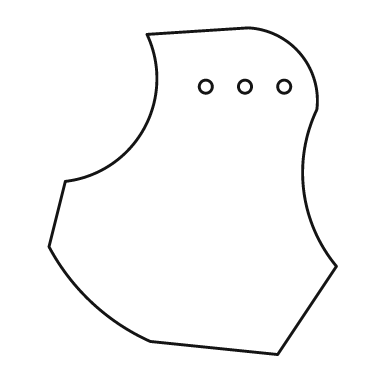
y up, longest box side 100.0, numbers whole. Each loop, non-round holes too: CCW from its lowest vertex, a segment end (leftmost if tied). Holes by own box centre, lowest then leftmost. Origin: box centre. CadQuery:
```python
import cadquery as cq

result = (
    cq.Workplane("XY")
    .moveTo(26.0, -50.0)
    .lineTo(44.0, -23.0)
    .threePointArc((34.0, 0.0), (38.0, 25.0))
    .threePointArc((33.0, 42.0), (17.0, 50.0))
    .lineTo(-14.0, 48.0)
    .threePointArc((-15.0, 19.0), (-39.0, 3.0))
    .lineTo(-44.0, -17.0)
    .threePointArc((-31.0, -34.0), (-13.0, -46.0))
    .close()
    .moveTo(4.0, 32.0)
    .circle(2.0)
    .moveTo(16.0, 32.0)
    .circle(2.0)
    .moveTo(28.0, 32.0)
    .circle(2.0)
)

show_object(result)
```